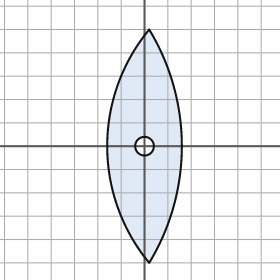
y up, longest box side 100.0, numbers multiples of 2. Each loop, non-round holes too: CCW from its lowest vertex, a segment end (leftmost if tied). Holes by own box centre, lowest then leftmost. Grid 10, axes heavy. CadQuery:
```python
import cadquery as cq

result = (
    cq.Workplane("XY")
    .moveTo(2.0, -50.0)
    .threePointArc((16.0, 0.0), (2.0, 50.0))
    .threePointArc((-16.0, 0.0), (2.0, -50.0))
    .close()
    .moveTo(0.0, 0.0)
    .circle(4.0)
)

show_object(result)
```